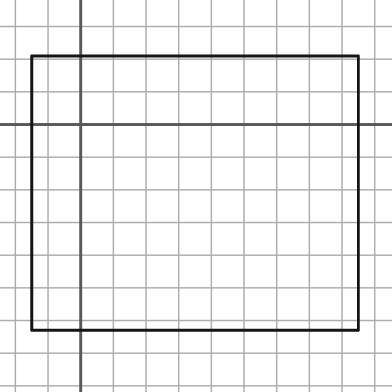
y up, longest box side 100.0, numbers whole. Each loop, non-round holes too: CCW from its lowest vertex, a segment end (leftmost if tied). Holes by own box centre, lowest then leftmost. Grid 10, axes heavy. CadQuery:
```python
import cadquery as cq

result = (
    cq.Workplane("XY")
    .moveTo(-15.0, -63.0)
    .lineTo(85.0, -63.0)
    .lineTo(85.0, 21.0)
    .lineTo(-15.0, 21.0)
    .close()
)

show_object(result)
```